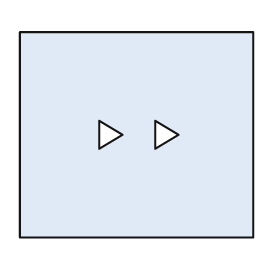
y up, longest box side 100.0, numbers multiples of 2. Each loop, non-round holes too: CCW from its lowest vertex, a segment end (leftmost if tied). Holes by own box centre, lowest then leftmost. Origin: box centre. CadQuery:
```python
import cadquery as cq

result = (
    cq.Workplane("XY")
    .moveTo(-50.0, -44.0)
    .lineTo(50.0, -44.0)
    .lineTo(50.0, 44.0)
    .lineTo(-50.0, 44.0)
    .close()
    .moveTo(-16.0, -6.0)
    .lineTo(-6.0, 0.0)
    .lineTo(-16.0, 6.0)
    .close()
    .moveTo(8.0, -6.0)
    .lineTo(18.0, 0.0)
    .lineTo(8.0, 6.0)
    .close()
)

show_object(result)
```